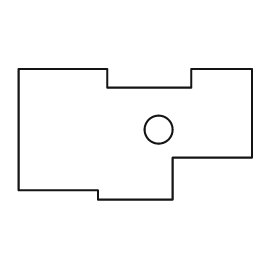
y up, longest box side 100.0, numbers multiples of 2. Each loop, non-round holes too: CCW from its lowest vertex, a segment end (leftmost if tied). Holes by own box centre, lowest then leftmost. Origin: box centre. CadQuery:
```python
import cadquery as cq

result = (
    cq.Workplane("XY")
    .moveTo(-16.0, -28.0)
    .lineTo(16.0, -28.0)
    .lineTo(16.0, -10.0)
    .lineTo(50.0, -10.0)
    .lineTo(50.0, 28.0)
    .lineTo(24.0, 28.0)
    .lineTo(24.0, 20.0)
    .lineTo(-12.0, 20.0)
    .lineTo(-12.0, 28.0)
    .lineTo(-50.0, 28.0)
    .lineTo(-50.0, -24.0)
    .lineTo(-16.0, -24.0)
    .close()
    .moveTo(10.0, 2.0)
    .circle(6.0)
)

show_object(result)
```